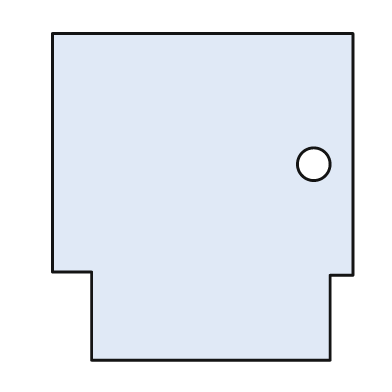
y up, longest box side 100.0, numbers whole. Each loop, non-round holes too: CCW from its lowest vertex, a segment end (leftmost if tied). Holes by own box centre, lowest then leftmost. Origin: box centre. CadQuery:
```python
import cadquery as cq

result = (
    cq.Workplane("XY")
    .moveTo(-34.0, -50.0)
    .lineTo(39.0, -50.0)
    .lineTo(39.0, -24.0)
    .lineTo(46.0, -24.0)
    .lineTo(46.0, 50.0)
    .lineTo(-46.0, 50.0)
    .lineTo(-46.0, -23.0)
    .lineTo(-34.0, -23.0)
    .close()
    .moveTo(34.0, 10.0)
    .circle(5.0)
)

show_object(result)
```